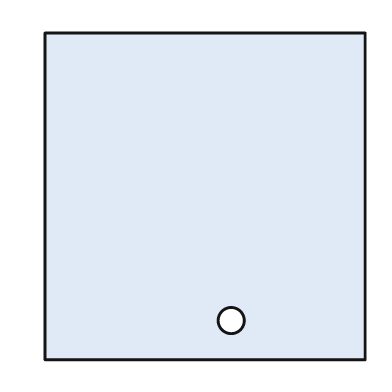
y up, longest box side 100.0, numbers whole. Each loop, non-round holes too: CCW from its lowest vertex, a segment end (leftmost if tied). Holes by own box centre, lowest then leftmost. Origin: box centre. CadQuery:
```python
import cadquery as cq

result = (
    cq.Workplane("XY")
    .moveTo(-49.0, -50.0)
    .lineTo(49.0, -50.0)
    .lineTo(49.0, 50.0)
    .lineTo(-49.0, 50.0)
    .close()
    .moveTo(8.0, -38.0)
    .circle(4.0)
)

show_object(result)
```